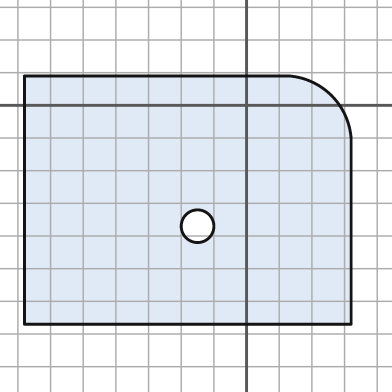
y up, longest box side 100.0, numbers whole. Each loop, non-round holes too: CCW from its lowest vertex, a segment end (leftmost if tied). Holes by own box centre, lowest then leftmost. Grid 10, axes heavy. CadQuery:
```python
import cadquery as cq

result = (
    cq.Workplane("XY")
    .moveTo(-68.0, -67.0)
    .lineTo(32.0, -67.0)
    .lineTo(32.0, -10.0)
    .threePointArc((26.0, 3.0), (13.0, 9.0))
    .lineTo(-68.0, 9.0)
    .close()
    .moveTo(-15.0, -37.0)
    .circle(5.0)
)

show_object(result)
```